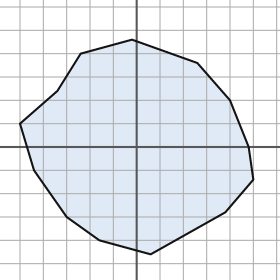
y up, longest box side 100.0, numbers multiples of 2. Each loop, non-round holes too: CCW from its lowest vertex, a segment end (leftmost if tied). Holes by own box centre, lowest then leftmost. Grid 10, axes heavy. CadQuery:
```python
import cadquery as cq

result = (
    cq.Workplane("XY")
    .moveTo(6.0, -46.0)
    .lineTo(38.0, -28.0)
    .lineTo(50.0, -14.0)
    .lineTo(48.0, 0.0)
    .lineTo(40.0, 20.0)
    .lineTo(26.0, 36.0)
    .lineTo(-2.0, 46.0)
    .lineTo(-24.0, 40.0)
    .lineTo(-34.0, 24.0)
    .lineTo(-50.0, 10.0)
    .lineTo(-44.0, -10.0)
    .lineTo(-30.0, -30.0)
    .lineTo(-16.0, -40.0)
    .close()
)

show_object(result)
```